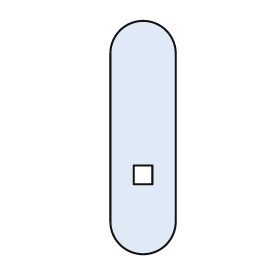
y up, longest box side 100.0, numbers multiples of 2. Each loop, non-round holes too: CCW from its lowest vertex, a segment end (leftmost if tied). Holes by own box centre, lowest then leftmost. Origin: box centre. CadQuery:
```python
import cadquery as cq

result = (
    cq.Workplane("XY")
    .moveTo(-14.0, -36.0)
    .threePointArc((0.0, -50.0), (14.0, -36.0))
    .lineTo(14.0, 36.0)
    .threePointArc((0.0, 50.0), (-14.0, 36.0))
    .close()
    .moveTo(-4.0, -20.0)
    .lineTo(4.0, -20.0)
    .lineTo(4.0, -12.0)
    .lineTo(-4.0, -12.0)
    .close()
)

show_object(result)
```